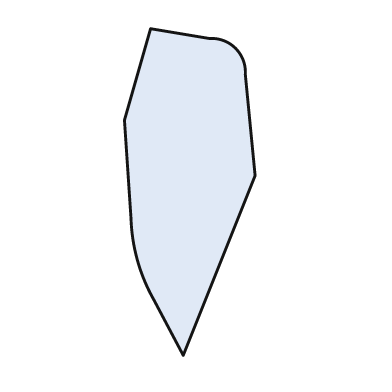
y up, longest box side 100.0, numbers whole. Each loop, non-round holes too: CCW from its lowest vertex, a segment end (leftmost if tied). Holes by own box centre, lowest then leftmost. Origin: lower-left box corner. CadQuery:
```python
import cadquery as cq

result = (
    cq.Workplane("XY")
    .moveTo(18.0, 0.0)
    .lineTo(40.0, 55.0)
    .lineTo(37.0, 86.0)
    .threePointArc((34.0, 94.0), (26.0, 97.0))
    .lineTo(8.0, 100.0)
    .lineTo(0.0, 72.0)
    .lineTo(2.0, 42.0)
    .threePointArc((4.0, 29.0), (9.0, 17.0))
    .close()
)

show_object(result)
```